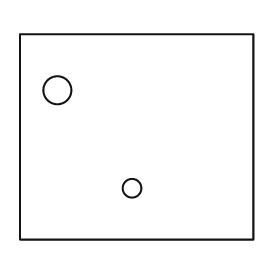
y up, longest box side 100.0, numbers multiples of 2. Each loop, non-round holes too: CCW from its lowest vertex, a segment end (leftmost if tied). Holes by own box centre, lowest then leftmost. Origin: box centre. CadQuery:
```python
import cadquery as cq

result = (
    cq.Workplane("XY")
    .moveTo(-50.0, -44.0)
    .lineTo(50.0, -44.0)
    .lineTo(50.0, 44.0)
    .lineTo(-50.0, 44.0)
    .close()
    .moveTo(-2.0, -22.0)
    .circle(4.0)
    .moveTo(-34.0, 20.0)
    .circle(6.0)
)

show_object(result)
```